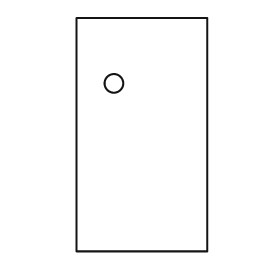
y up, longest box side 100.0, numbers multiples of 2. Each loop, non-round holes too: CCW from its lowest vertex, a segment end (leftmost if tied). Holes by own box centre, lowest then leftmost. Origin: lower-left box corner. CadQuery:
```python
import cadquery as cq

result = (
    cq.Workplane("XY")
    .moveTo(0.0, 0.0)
    .lineTo(56.0, 0.0)
    .lineTo(56.0, 100.0)
    .lineTo(0.0, 100.0)
    .close()
    .moveTo(16.0, 72.0)
    .circle(4.0)
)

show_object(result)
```